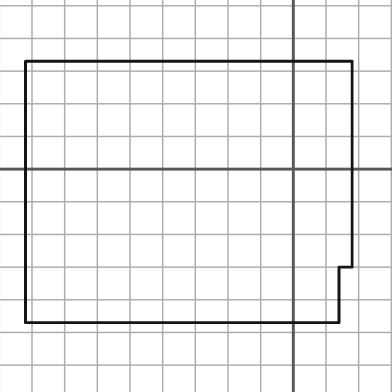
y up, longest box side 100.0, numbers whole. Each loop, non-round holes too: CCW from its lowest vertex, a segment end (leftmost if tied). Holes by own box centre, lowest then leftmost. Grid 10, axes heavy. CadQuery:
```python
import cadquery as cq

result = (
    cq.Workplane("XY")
    .moveTo(-82.0, -47.0)
    .lineTo(14.0, -47.0)
    .lineTo(14.0, -30.0)
    .lineTo(18.0, -30.0)
    .lineTo(18.0, 33.0)
    .lineTo(-82.0, 33.0)
    .close()
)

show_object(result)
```